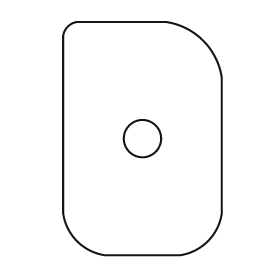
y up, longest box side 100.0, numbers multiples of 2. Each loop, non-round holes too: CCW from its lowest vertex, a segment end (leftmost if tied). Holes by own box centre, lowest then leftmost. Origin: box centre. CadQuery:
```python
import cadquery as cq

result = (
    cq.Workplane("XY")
    .moveTo(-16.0, -50.0)
    .lineTo(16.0, -50.0)
    .threePointArc((28.0, -44.0), (34.0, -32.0))
    .lineTo(34.0, 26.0)
    .threePointArc((26.0, 42.0), (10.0, 50.0))
    .lineTo(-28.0, 50.0)
    .threePointArc((-32.0, 48.0), (-34.0, 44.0))
    .lineTo(-34.0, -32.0)
    .threePointArc((-28.0, -44.0), (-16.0, -50.0))
    .close()
    .moveTo(0.0, 0.0)
    .circle(8.0)
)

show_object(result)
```